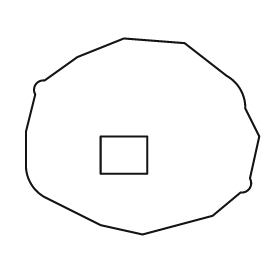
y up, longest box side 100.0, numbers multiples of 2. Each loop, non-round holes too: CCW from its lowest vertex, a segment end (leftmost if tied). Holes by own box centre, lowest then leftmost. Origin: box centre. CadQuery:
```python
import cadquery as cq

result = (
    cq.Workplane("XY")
    .moveTo(0.0, -42.0)
    .lineTo(30.0, -34.0)
    .lineTo(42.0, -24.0)
    .threePointArc((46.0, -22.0), (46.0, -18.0))
    .lineTo(50.0, 0.0)
    .lineTo(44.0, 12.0)
    .threePointArc((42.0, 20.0), (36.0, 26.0))
    .lineTo(18.0, 40.0)
    .lineTo(-8.0, 42.0)
    .lineTo(-28.0, 34.0)
    .lineTo(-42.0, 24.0)
    .threePointArc((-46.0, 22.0), (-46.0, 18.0))
    .lineTo(-50.0, 2.0)
    .lineTo(-50.0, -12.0)
    .threePointArc((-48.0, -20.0), (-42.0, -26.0))
    .lineTo(-18.0, -38.0)
    .close()
    .moveTo(-18.0, -16.0)
    .lineTo(2.0, -16.0)
    .lineTo(2.0, 0.0)
    .lineTo(-18.0, 0.0)
    .close()
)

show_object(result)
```